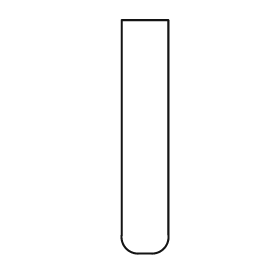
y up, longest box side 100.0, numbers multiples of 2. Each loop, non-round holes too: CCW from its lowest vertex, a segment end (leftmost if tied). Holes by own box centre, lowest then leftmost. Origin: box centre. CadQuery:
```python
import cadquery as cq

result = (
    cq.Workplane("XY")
    .moveTo(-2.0, -50.0)
    .lineTo(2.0, -50.0)
    .threePointArc((8.0, -48.0), (10.0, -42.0))
    .lineTo(10.0, 50.0)
    .lineTo(-10.0, 50.0)
    .lineTo(-10.0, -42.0)
    .threePointArc((-8.0, -48.0), (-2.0, -50.0))
    .close()
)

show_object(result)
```